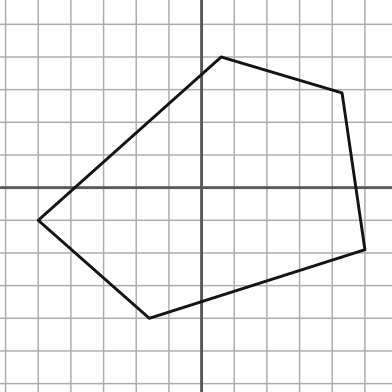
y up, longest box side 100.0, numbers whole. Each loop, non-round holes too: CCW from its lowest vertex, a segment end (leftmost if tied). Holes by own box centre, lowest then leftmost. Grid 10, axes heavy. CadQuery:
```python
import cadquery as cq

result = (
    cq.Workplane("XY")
    .moveTo(-16.0, -40.0)
    .lineTo(50.0, -19.0)
    .lineTo(43.0, 29.0)
    .lineTo(6.0, 40.0)
    .lineTo(-50.0, -10.0)
    .close()
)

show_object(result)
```